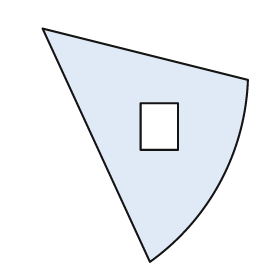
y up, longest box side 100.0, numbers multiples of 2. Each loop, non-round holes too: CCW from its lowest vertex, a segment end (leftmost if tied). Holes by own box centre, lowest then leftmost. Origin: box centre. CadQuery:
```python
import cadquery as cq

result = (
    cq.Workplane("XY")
    .moveTo(2.0, -50.0)
    .threePointArc((32.0, -16.0), (44.0, 28.0))
    .lineTo(-44.0, 50.0)
    .close()
    .moveTo(-2.0, -2.0)
    .lineTo(14.0, -2.0)
    .lineTo(14.0, 18.0)
    .lineTo(-2.0, 18.0)
    .close()
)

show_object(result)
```